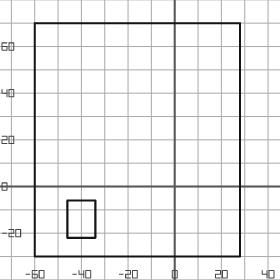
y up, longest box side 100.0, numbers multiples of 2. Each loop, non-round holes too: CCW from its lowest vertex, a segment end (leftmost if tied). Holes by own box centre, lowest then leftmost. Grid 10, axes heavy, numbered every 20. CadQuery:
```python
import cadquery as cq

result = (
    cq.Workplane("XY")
    .moveTo(-60.0, -30.0)
    .lineTo(28.0, -30.0)
    .lineTo(28.0, 70.0)
    .lineTo(-60.0, 70.0)
    .close()
    .moveTo(-46.0, -22.0)
    .lineTo(-34.0, -22.0)
    .lineTo(-34.0, -6.0)
    .lineTo(-46.0, -6.0)
    .close()
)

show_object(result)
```